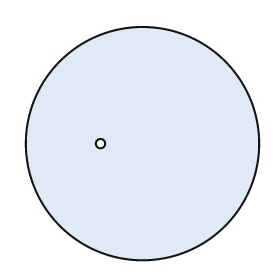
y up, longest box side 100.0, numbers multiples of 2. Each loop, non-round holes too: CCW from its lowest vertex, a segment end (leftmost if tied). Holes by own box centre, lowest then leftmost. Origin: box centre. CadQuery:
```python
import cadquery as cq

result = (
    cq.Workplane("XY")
    .moveTo(0.0, 0.0)
    .circle(50.0)
    .moveTo(-18.0, 0.0)
    .circle(2.0)
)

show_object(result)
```